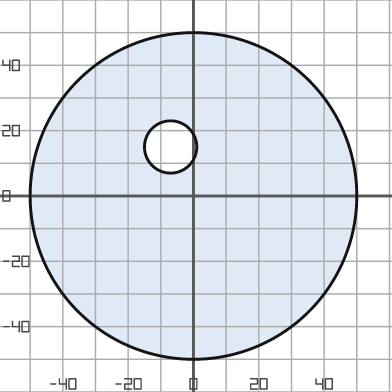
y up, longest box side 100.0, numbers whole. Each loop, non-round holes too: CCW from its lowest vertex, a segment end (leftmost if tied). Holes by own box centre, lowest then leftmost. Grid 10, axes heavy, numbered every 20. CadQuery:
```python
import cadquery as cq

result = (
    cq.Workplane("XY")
    .moveTo(0.0, 0.0)
    .circle(50.0)
    .moveTo(-7.0, 15.0)
    .circle(8.0)
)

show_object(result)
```